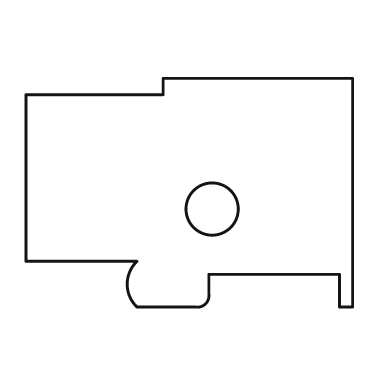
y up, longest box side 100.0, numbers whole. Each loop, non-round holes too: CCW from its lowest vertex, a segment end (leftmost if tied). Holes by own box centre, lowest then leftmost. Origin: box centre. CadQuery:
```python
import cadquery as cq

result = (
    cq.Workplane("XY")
    .moveTo(-16.0, -35.0)
    .lineTo(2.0, -35.0)
    .threePointArc((5.0, -34.0), (6.0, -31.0))
    .lineTo(6.0, -25.0)
    .lineTo(46.0, -25.0)
    .lineTo(46.0, -35.0)
    .lineTo(50.0, -35.0)
    .lineTo(50.0, 35.0)
    .lineTo(-8.0, 35.0)
    .lineTo(-8.0, 30.0)
    .lineTo(-50.0, 30.0)
    .lineTo(-50.0, -21.0)
    .lineTo(-16.0, -21.0)
    .threePointArc((-19.0, -28.0), (-16.0, -35.0))
    .close()
    .moveTo(7.0, -5.0)
    .circle(8.0)
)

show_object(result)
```